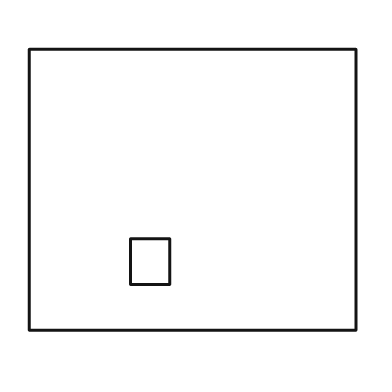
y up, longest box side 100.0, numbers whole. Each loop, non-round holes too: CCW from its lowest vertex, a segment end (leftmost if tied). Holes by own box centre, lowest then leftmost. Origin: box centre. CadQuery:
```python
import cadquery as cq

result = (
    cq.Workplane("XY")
    .moveTo(-50.0, -43.0)
    .lineTo(50.0, -43.0)
    .lineTo(50.0, 43.0)
    .lineTo(-50.0, 43.0)
    .close()
    .moveTo(-19.0, -29.0)
    .lineTo(-7.0, -29.0)
    .lineTo(-7.0, -15.0)
    .lineTo(-19.0, -15.0)
    .close()
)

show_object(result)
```